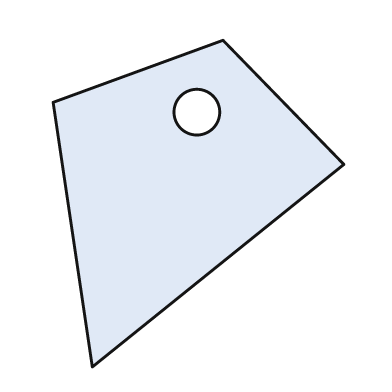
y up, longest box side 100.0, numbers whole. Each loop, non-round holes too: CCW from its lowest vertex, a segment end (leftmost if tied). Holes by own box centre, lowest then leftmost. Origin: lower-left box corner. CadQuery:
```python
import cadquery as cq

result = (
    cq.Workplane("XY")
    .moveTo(12.0, 0.0)
    .lineTo(89.0, 62.0)
    .lineTo(52.0, 100.0)
    .lineTo(0.0, 81.0)
    .close()
    .moveTo(44.0, 78.0)
    .circle(7.0)
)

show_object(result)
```